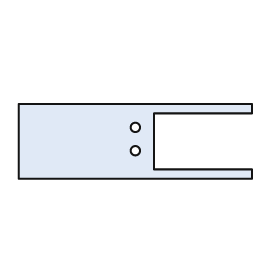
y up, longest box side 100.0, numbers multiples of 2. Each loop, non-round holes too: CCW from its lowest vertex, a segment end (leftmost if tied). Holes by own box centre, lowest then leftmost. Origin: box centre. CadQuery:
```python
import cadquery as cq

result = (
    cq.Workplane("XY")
    .moveTo(-50.0, -16.0)
    .lineTo(50.0, -16.0)
    .lineTo(50.0, -12.0)
    .lineTo(8.0, -12.0)
    .lineTo(8.0, 12.0)
    .lineTo(50.0, 12.0)
    .lineTo(50.0, 16.0)
    .lineTo(-50.0, 16.0)
    .close()
    .moveTo(0.0, -4.0)
    .circle(2.0)
    .moveTo(0.0, 6.0)
    .circle(2.0)
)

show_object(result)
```